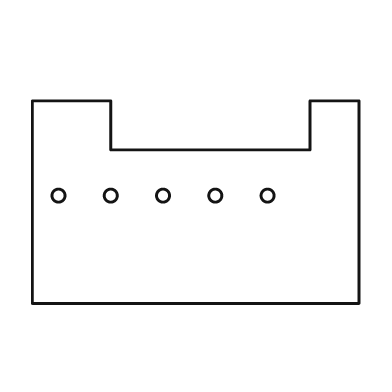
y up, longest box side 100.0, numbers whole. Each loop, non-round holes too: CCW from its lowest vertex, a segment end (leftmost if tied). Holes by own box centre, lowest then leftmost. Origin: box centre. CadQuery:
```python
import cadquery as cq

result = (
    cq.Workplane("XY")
    .moveTo(-50.0, -31.0)
    .lineTo(50.0, -31.0)
    .lineTo(50.0, 31.0)
    .lineTo(35.0, 31.0)
    .lineTo(35.0, 16.0)
    .lineTo(-26.0, 16.0)
    .lineTo(-26.0, 31.0)
    .lineTo(-50.0, 31.0)
    .close()
    .moveTo(-42.0, 2.0)
    .circle(2.0)
    .moveTo(-26.0, 2.0)
    .circle(2.0)
    .moveTo(-10.0, 2.0)
    .circle(2.0)
    .moveTo(6.0, 2.0)
    .circle(2.0)
    .moveTo(22.0, 2.0)
    .circle(2.0)
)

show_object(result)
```